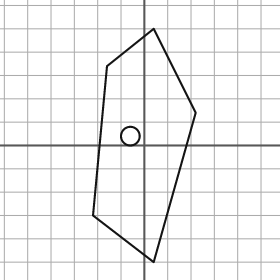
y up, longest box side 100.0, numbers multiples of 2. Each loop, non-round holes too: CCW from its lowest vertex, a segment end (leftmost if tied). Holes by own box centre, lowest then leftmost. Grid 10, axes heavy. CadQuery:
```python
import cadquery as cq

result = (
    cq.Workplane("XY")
    .moveTo(4.0, -50.0)
    .lineTo(22.0, 14.0)
    .lineTo(4.0, 50.0)
    .lineTo(-16.0, 34.0)
    .lineTo(-22.0, -30.0)
    .close()
    .moveTo(-6.0, 4.0)
    .circle(4.0)
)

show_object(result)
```